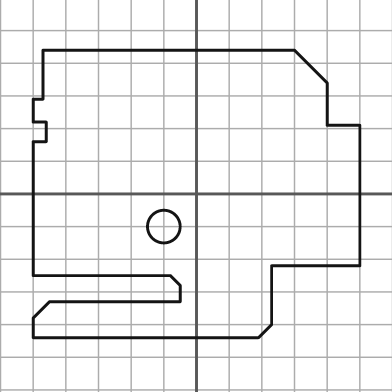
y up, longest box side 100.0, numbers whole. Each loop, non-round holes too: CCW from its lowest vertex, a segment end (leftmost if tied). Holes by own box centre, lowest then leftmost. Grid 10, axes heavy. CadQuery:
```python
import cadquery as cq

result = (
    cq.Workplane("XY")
    .moveTo(-50.0, -44.0)
    .lineTo(19.0, -44.0)
    .lineTo(23.0, -40.0)
    .lineTo(23.0, -22.0)
    .lineTo(50.0, -22.0)
    .lineTo(50.0, 21.0)
    .lineTo(40.0, 21.0)
    .lineTo(40.0, 34.0)
    .lineTo(30.0, 44.0)
    .lineTo(-47.0, 44.0)
    .lineTo(-47.0, 29.0)
    .lineTo(-50.0, 29.0)
    .lineTo(-50.0, 22.0)
    .lineTo(-46.0, 22.0)
    .lineTo(-46.0, 16.0)
    .lineTo(-50.0, 16.0)
    .lineTo(-50.0, -25.0)
    .lineTo(-8.0, -25.0)
    .lineTo(-5.0, -28.0)
    .lineTo(-5.0, -33.0)
    .lineTo(-45.0, -33.0)
    .lineTo(-50.0, -38.0)
    .close()
    .moveTo(-10.0, -10.0)
    .circle(5.0)
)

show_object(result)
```